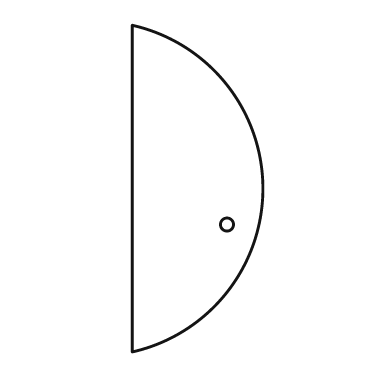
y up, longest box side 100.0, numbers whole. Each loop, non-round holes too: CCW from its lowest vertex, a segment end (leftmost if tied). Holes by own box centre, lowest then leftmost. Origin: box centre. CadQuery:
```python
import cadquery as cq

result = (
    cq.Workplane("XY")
    .moveTo(-20.0, -50.0)
    .threePointArc((20.0, 0.0), (-20.0, 50.0))
    .close()
    .moveTo(9.0, -11.0)
    .circle(2.0)
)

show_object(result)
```